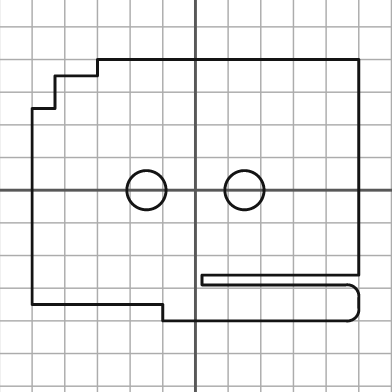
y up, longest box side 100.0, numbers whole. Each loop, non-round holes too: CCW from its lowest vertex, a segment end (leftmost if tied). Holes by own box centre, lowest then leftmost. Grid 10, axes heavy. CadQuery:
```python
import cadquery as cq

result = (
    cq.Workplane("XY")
    .moveTo(-10.0, -40.0)
    .lineTo(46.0, -40.0)
    .threePointArc((49.0, -39.0), (50.0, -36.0))
    .lineTo(50.0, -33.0)
    .threePointArc((49.0, -30.0), (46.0, -29.0))
    .lineTo(2.0, -29.0)
    .lineTo(2.0, -26.0)
    .lineTo(50.0, -26.0)
    .lineTo(50.0, 40.0)
    .lineTo(-30.0, 40.0)
    .lineTo(-30.0, 35.0)
    .lineTo(-43.0, 35.0)
    .lineTo(-43.0, 25.0)
    .lineTo(-50.0, 25.0)
    .lineTo(-50.0, -35.0)
    .lineTo(-10.0, -35.0)
    .close()
    .moveTo(-15.0, 0.0)
    .circle(6.0)
    .moveTo(15.0, 0.0)
    .circle(6.0)
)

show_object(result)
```